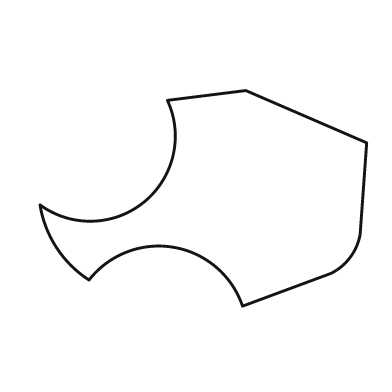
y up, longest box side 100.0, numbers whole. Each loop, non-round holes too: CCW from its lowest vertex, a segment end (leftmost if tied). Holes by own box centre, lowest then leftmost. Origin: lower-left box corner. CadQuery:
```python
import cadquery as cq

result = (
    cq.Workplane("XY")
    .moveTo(62.0, 0.0)
    .lineTo(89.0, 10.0)
    .threePointArc((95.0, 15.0), (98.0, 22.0))
    .lineTo(100.0, 50.0)
    .lineTo(63.0, 66.0)
    .lineTo(39.0, 63.0)
    .threePointArc((32.0, 32.0), (0.0, 31.0))
    .threePointArc((5.0, 18.0), (15.0, 8.0))
    .threePointArc((41.0, 18.0), (62.0, 0.0))
    .close()
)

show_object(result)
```